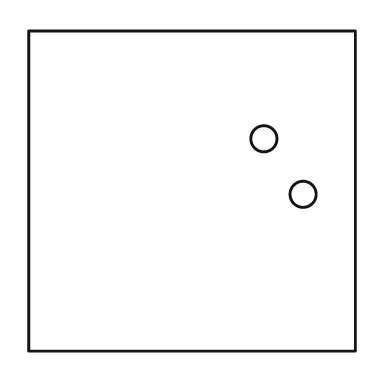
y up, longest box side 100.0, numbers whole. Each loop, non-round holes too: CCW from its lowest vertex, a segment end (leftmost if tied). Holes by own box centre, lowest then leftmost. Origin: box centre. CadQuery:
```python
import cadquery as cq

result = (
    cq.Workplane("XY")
    .moveTo(-50.0, -49.0)
    .lineTo(50.0, -49.0)
    .lineTo(50.0, 49.0)
    .lineTo(-50.0, 49.0)
    .close()
    .moveTo(34.0, -1.0)
    .circle(4.0)
    .moveTo(22.0, 16.0)
    .circle(4.0)
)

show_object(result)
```